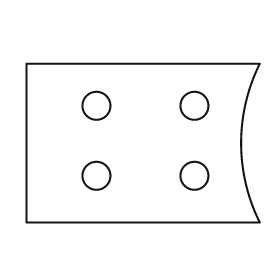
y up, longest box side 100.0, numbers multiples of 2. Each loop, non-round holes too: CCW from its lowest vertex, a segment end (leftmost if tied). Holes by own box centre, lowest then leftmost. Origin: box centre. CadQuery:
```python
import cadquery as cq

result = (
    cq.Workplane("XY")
    .moveTo(-50.0, -34.0)
    .lineTo(50.0, -34.0)
    .threePointArc((42.0, 0.0), (50.0, 34.0))
    .lineTo(-50.0, 34.0)
    .close()
    .moveTo(-20.0, -14.0)
    .circle(6.0)
    .moveTo(22.0, -14.0)
    .circle(6.0)
    .moveTo(-20.0, 16.0)
    .circle(6.0)
    .moveTo(22.0, 16.0)
    .circle(6.0)
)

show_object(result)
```